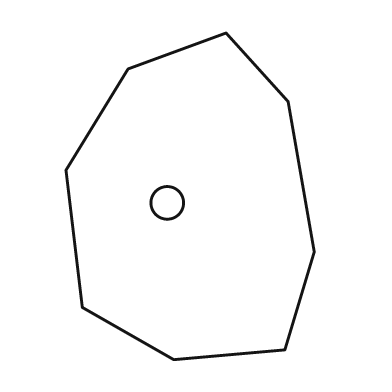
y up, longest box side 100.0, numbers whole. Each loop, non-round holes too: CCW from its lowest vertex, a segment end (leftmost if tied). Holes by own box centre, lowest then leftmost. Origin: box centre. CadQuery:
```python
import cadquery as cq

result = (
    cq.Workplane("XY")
    .moveTo(-5.0, -50.0)
    .lineTo(29.0, -47.0)
    .lineTo(38.0, -17.0)
    .lineTo(30.0, 29.0)
    .lineTo(11.0, 50.0)
    .lineTo(-19.0, 39.0)
    .lineTo(-38.0, 8.0)
    .lineTo(-33.0, -34.0)
    .close()
    .moveTo(-7.0, -2.0)
    .circle(5.0)
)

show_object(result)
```